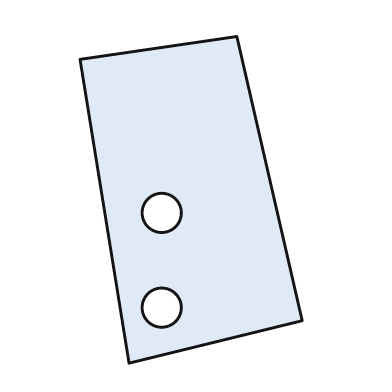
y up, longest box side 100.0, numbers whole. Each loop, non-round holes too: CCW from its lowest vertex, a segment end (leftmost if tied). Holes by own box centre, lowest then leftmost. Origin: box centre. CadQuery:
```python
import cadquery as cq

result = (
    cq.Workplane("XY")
    .moveTo(-19.0, -50.0)
    .lineTo(34.0, -37.0)
    .lineTo(14.0, 50.0)
    .lineTo(-34.0, 43.0)
    .close()
    .moveTo(-9.0, -33.0)
    .circle(6.0)
    .moveTo(-9.0, -4.0)
    .circle(6.0)
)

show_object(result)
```